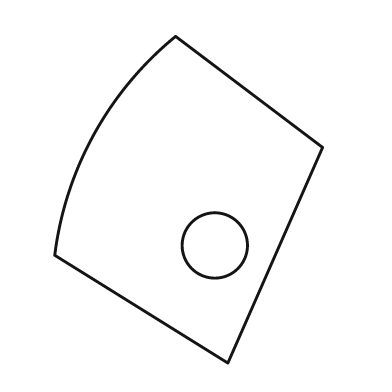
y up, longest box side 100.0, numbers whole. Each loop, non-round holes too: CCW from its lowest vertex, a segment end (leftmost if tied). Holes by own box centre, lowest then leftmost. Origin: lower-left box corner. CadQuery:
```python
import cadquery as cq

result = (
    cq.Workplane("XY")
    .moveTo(53.0, 0.0)
    .lineTo(82.0, 66.0)
    .lineTo(37.0, 100.0)
    .threePointArc((12.0, 70.0), (0.0, 33.0))
    .close()
    .moveTo(49.0, 36.0)
    .circle(10.0)
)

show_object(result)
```